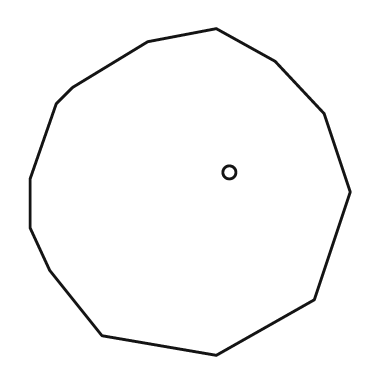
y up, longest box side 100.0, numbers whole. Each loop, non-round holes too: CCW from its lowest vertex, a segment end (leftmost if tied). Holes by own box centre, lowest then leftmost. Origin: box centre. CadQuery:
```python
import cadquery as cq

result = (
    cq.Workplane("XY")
    .moveTo(8.0, -50.0)
    .lineTo(38.0, -33.0)
    .lineTo(49.0, 0.0)
    .lineTo(41.0, 24.0)
    .lineTo(26.0, 40.0)
    .lineTo(8.0, 50.0)
    .lineTo(-13.0, 46.0)
    .lineTo(-36.0, 32.0)
    .lineTo(-41.0, 27.0)
    .lineTo(-49.0, 4.0)
    .lineTo(-49.0, -11.0)
    .lineTo(-43.0, -24.0)
    .lineTo(-27.0, -44.0)
    .close()
    .moveTo(12.0, 6.0)
    .circle(2.0)
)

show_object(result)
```